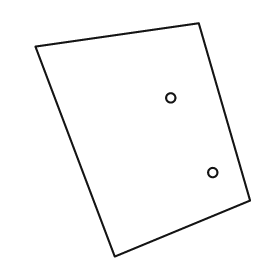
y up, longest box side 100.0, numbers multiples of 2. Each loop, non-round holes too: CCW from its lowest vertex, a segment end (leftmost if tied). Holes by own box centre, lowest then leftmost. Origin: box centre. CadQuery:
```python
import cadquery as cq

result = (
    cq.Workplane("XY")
    .moveTo(-12.0, -50.0)
    .lineTo(46.0, -26.0)
    .lineTo(24.0, 50.0)
    .lineTo(-46.0, 40.0)
    .close()
    .moveTo(30.0, -14.0)
    .circle(2.0)
    .moveTo(12.0, 18.0)
    .circle(2.0)
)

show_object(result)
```